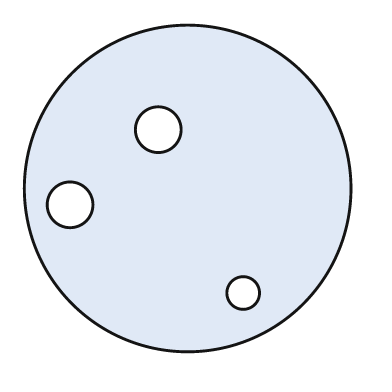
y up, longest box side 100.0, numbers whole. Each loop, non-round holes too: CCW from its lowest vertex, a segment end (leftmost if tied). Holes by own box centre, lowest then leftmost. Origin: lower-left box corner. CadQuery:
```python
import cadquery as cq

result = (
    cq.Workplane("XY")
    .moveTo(50.0, 50.0)
    .circle(50.0)
    .moveTo(67.0, 18.0)
    .circle(5.0)
    .moveTo(14.0, 45.0)
    .circle(7.0)
    .moveTo(41.0, 68.0)
    .circle(7.0)
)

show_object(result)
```